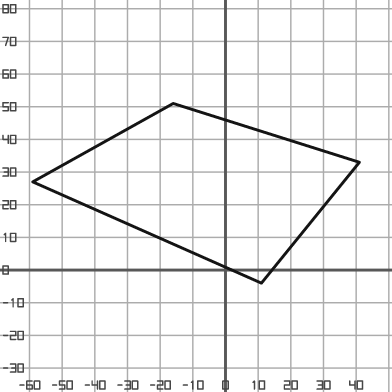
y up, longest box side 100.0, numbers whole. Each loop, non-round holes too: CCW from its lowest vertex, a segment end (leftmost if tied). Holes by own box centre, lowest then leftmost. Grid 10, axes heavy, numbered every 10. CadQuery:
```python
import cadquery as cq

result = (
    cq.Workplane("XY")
    .moveTo(11.0, -4.0)
    .lineTo(41.0, 33.0)
    .lineTo(-16.0, 51.0)
    .lineTo(-59.0, 27.0)
    .close()
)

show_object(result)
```